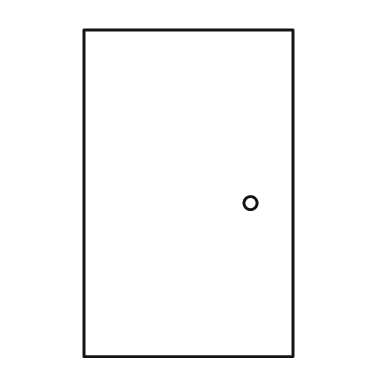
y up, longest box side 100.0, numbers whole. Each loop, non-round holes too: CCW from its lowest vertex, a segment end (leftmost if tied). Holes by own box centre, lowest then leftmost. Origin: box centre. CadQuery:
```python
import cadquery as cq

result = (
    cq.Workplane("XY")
    .moveTo(-32.0, -50.0)
    .lineTo(32.0, -50.0)
    .lineTo(32.0, 50.0)
    .lineTo(-32.0, 50.0)
    .close()
    .moveTo(19.0, -3.0)
    .circle(2.0)
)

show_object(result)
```